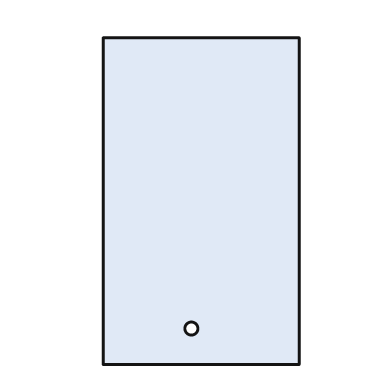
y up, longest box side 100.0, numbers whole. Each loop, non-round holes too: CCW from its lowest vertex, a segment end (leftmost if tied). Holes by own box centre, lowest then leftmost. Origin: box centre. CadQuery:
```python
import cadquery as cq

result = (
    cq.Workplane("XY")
    .moveTo(-30.0, -50.0)
    .lineTo(30.0, -50.0)
    .lineTo(30.0, 50.0)
    .lineTo(-30.0, 50.0)
    .close()
    .moveTo(-3.0, -39.0)
    .circle(2.0)
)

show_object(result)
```